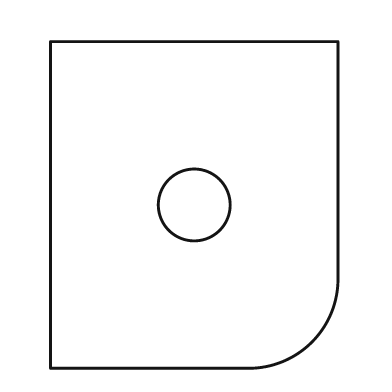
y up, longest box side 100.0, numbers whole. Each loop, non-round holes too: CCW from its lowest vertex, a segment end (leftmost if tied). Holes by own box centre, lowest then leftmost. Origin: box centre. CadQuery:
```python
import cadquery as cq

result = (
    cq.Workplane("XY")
    .moveTo(-44.0, -50.0)
    .lineTo(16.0, -50.0)
    .threePointArc((36.0, -42.0), (44.0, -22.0))
    .lineTo(44.0, 50.0)
    .lineTo(-44.0, 50.0)
    .close()
    .moveTo(0.0, 0.0)
    .circle(11.0)
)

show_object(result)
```